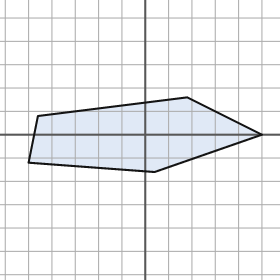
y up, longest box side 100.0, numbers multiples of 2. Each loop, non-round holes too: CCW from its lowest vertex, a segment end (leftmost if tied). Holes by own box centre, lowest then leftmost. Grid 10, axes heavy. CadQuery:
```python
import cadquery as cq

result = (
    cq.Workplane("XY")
    .moveTo(4.0, -16.0)
    .lineTo(50.0, 0.0)
    .lineTo(18.0, 16.0)
    .lineTo(-46.0, 8.0)
    .lineTo(-50.0, -12.0)
    .close()
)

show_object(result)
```